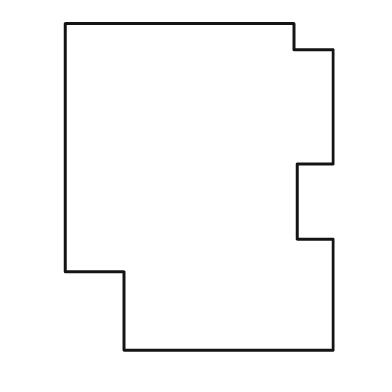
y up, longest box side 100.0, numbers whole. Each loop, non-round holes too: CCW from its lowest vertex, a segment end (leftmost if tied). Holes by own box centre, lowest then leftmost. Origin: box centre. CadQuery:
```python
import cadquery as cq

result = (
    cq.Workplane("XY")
    .moveTo(-23.0, -50.0)
    .lineTo(41.0, -50.0)
    .lineTo(41.0, -16.0)
    .lineTo(30.0, -16.0)
    .lineTo(30.0, 7.0)
    .lineTo(41.0, 7.0)
    .lineTo(41.0, 42.0)
    .lineTo(29.0, 42.0)
    .lineTo(29.0, 50.0)
    .lineTo(-41.0, 50.0)
    .lineTo(-41.0, -26.0)
    .lineTo(-23.0, -26.0)
    .close()
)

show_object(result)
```